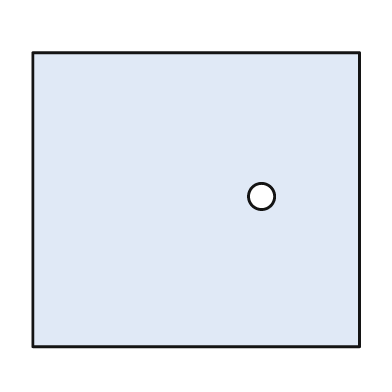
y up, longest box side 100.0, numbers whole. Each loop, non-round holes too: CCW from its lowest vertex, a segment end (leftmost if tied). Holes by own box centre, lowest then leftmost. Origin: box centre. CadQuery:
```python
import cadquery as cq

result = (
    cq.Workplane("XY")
    .moveTo(-50.0, -45.0)
    .lineTo(50.0, -45.0)
    .lineTo(50.0, 45.0)
    .lineTo(-50.0, 45.0)
    .close()
    .moveTo(20.0, 1.0)
    .circle(4.0)
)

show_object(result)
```